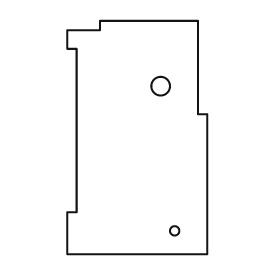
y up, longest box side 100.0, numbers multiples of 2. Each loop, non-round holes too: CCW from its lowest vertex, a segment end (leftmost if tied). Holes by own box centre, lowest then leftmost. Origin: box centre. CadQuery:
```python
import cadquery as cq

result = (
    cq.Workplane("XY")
    .moveTo(-30.0, -50.0)
    .lineTo(30.0, -50.0)
    .lineTo(30.0, 10.0)
    .lineTo(26.0, 10.0)
    .lineTo(26.0, 50.0)
    .lineTo(-16.0, 50.0)
    .lineTo(-16.0, 46.0)
    .lineTo(-30.0, 46.0)
    .lineTo(-30.0, 38.0)
    .lineTo(-26.0, 38.0)
    .lineTo(-26.0, -32.0)
    .lineTo(-30.0, -32.0)
    .close()
    .moveTo(16.0, -40.0)
    .circle(2.0)
    .moveTo(10.0, 22.0)
    .circle(4.0)
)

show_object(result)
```